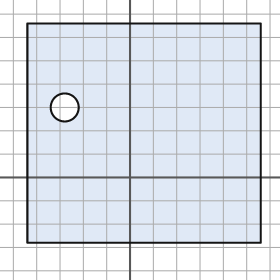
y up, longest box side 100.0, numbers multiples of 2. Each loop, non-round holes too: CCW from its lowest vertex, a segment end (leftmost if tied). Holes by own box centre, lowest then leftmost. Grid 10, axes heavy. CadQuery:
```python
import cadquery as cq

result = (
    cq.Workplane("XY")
    .moveTo(-44.0, -28.0)
    .lineTo(56.0, -28.0)
    .lineTo(56.0, 66.0)
    .lineTo(-44.0, 66.0)
    .close()
    .moveTo(-28.0, 30.0)
    .circle(6.0)
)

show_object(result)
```